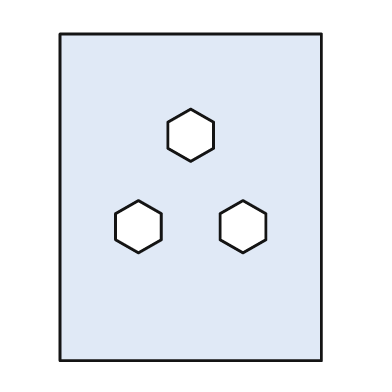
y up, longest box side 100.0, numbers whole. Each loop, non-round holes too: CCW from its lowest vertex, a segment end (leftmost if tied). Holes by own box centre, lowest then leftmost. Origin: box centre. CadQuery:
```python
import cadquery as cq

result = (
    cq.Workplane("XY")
    .moveTo(-40.0, -50.0)
    .lineTo(40.0, -50.0)
    .lineTo(40.0, 50.0)
    .lineTo(-40.0, 50.0)
    .close()
    .moveTo(-16.0, -17.0)
    .lineTo(-9.0, -13.0)
    .lineTo(-9.0, -5.0)
    .lineTo(-16.0, -1.0)
    .lineTo(-23.0, -5.0)
    .lineTo(-23.0, -13.0)
    .close()
    .moveTo(16.0, -17.0)
    .lineTo(23.0, -13.0)
    .lineTo(23.0, -5.0)
    .lineTo(16.0, -1.0)
    .lineTo(9.0, -5.0)
    .lineTo(9.0, -13.0)
    .close()
    .moveTo(0.0, 11.0)
    .lineTo(7.0, 15.0)
    .lineTo(7.0, 23.0)
    .lineTo(0.0, 27.0)
    .lineTo(-7.0, 23.0)
    .lineTo(-7.0, 15.0)
    .close()
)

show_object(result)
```